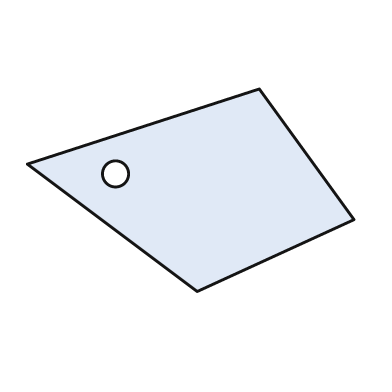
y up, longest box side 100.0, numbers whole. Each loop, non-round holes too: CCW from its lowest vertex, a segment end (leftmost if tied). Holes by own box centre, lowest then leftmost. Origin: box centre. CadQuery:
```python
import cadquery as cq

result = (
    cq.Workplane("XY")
    .moveTo(2.0, -31.0)
    .lineTo(50.0, -9.0)
    .lineTo(21.0, 31.0)
    .lineTo(-50.0, 8.0)
    .close()
    .moveTo(-23.0, 5.0)
    .circle(4.0)
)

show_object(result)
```